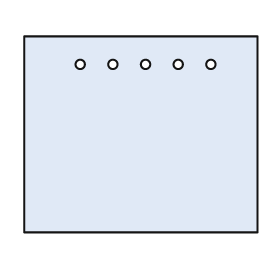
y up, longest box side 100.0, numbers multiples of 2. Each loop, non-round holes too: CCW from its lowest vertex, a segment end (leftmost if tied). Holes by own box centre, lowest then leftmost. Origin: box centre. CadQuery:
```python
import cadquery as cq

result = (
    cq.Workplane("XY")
    .moveTo(-50.0, -42.0)
    .lineTo(50.0, -42.0)
    .lineTo(50.0, 42.0)
    .lineTo(-50.0, 42.0)
    .close()
    .moveTo(-26.0, 30.0)
    .circle(2.0)
    .moveTo(-12.0, 30.0)
    .circle(2.0)
    .moveTo(2.0, 30.0)
    .circle(2.0)
    .moveTo(16.0, 30.0)
    .circle(2.0)
    .moveTo(30.0, 30.0)
    .circle(2.0)
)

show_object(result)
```